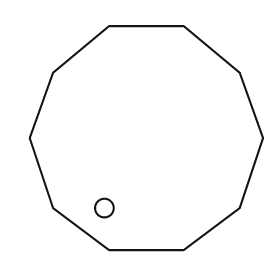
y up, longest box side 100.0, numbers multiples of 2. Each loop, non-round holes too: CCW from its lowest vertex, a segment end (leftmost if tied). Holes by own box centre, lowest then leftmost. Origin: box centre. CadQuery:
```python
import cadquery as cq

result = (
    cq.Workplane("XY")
    .moveTo(-16.0, -48.0)
    .lineTo(16.0, -48.0)
    .lineTo(40.0, -30.0)
    .lineTo(50.0, 0.0)
    .lineTo(40.0, 28.0)
    .lineTo(16.0, 48.0)
    .lineTo(-16.0, 48.0)
    .lineTo(-40.0, 28.0)
    .lineTo(-50.0, 0.0)
    .lineTo(-40.0, -30.0)
    .close()
    .moveTo(-18.0, -30.0)
    .circle(4.0)
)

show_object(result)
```